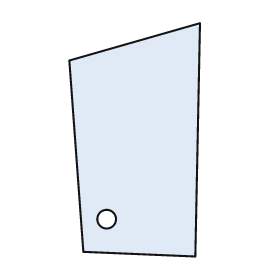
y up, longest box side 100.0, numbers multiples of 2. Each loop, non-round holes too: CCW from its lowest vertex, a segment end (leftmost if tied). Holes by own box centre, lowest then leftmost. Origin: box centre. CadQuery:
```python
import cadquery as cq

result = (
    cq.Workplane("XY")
    .moveTo(26.0, -50.0)
    .lineTo(28.0, 50.0)
    .lineTo(-28.0, 34.0)
    .lineTo(-22.0, -48.0)
    .close()
    .moveTo(-12.0, -34.0)
    .circle(4.0)
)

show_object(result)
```